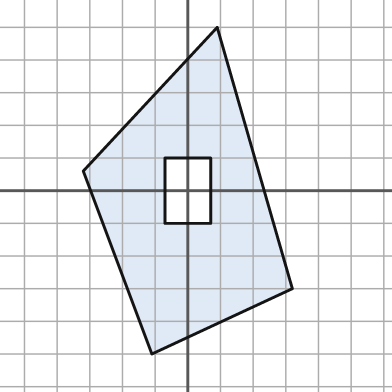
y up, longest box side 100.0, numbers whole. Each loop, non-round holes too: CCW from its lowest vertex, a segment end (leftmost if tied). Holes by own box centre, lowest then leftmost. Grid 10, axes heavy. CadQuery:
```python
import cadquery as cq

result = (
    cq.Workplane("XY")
    .moveTo(-11.0, -50.0)
    .lineTo(32.0, -30.0)
    .lineTo(9.0, 50.0)
    .lineTo(-32.0, 6.0)
    .close()
    .moveTo(-7.0, -10.0)
    .lineTo(7.0, -10.0)
    .lineTo(7.0, 10.0)
    .lineTo(-7.0, 10.0)
    .close()
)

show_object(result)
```